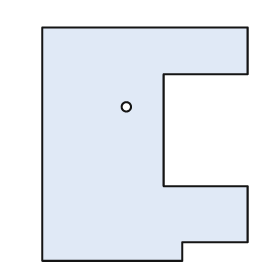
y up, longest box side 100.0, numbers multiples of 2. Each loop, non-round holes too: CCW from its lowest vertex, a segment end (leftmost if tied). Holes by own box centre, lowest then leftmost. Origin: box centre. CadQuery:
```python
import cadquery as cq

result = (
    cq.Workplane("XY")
    .moveTo(-44.0, -50.0)
    .lineTo(16.0, -50.0)
    .lineTo(16.0, -42.0)
    .lineTo(44.0, -42.0)
    .lineTo(44.0, -18.0)
    .lineTo(8.0, -18.0)
    .lineTo(8.0, 30.0)
    .lineTo(44.0, 30.0)
    .lineTo(44.0, 50.0)
    .lineTo(-44.0, 50.0)
    .close()
    .moveTo(-8.0, 16.0)
    .circle(2.0)
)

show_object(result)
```